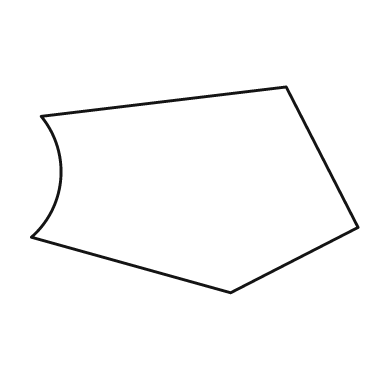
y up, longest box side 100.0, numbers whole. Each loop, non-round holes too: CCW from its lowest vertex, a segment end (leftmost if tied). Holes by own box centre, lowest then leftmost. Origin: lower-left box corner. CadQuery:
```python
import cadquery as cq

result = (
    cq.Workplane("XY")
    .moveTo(61.0, 0.0)
    .lineTo(100.0, 20.0)
    .lineTo(78.0, 63.0)
    .lineTo(3.0, 54.0)
    .threePointArc((9.0, 35.0), (0.0, 17.0))
    .close()
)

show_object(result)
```